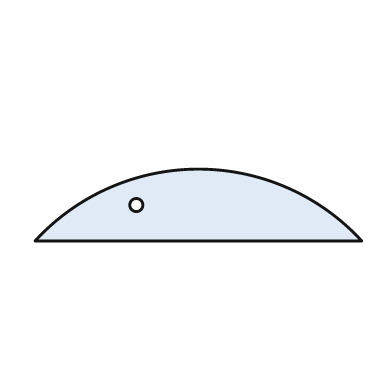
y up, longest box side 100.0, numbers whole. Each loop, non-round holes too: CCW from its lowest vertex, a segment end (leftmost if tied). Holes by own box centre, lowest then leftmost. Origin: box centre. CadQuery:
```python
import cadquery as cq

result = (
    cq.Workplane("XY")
    .moveTo(-50.0, -11.0)
    .lineTo(50.0, -11.0)
    .threePointArc((0.0, 11.0), (-50.0, -11.0))
    .close()
    .moveTo(-19.0, 0.0)
    .circle(2.0)
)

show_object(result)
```